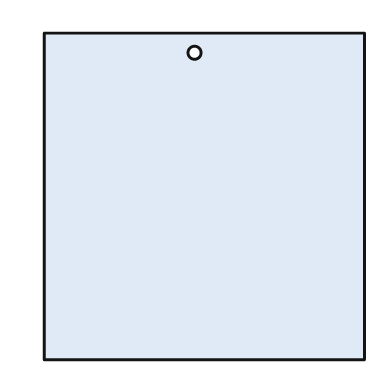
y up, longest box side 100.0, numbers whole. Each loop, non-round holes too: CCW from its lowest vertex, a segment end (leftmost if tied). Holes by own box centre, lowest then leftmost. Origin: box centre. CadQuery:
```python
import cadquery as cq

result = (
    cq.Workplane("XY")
    .moveTo(-49.0, -50.0)
    .lineTo(49.0, -50.0)
    .lineTo(49.0, 50.0)
    .lineTo(-49.0, 50.0)
    .close()
    .moveTo(-3.0, 44.0)
    .circle(2.0)
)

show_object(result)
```